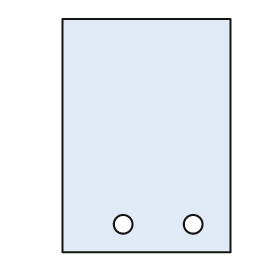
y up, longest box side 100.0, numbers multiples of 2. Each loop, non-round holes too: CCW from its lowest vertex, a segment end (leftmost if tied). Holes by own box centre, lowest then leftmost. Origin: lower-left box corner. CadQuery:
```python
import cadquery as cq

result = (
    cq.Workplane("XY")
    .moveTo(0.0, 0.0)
    .lineTo(72.0, 0.0)
    .lineTo(72.0, 100.0)
    .lineTo(0.0, 100.0)
    .close()
    .moveTo(26.0, 12.0)
    .circle(4.0)
    .moveTo(56.0, 12.0)
    .circle(4.0)
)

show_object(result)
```